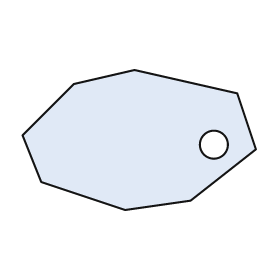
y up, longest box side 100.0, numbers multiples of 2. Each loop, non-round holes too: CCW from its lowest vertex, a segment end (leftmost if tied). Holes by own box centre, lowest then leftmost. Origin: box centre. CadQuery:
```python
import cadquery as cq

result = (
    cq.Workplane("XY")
    .moveTo(-6.0, -30.0)
    .lineTo(22.0, -26.0)
    .lineTo(50.0, -4.0)
    .lineTo(42.0, 20.0)
    .lineTo(-2.0, 30.0)
    .lineTo(-28.0, 24.0)
    .lineTo(-50.0, 2.0)
    .lineTo(-42.0, -18.0)
    .close()
    .moveTo(32.0, -2.0)
    .circle(6.0)
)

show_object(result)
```